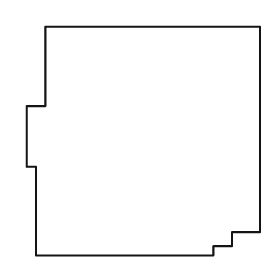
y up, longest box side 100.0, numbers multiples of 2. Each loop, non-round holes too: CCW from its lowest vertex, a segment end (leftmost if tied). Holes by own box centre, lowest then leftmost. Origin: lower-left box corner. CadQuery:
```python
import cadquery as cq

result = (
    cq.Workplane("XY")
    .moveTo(4.0, 0.0)
    .lineTo(80.0, 0.0)
    .lineTo(80.0, 4.0)
    .lineTo(88.0, 4.0)
    .lineTo(88.0, 10.0)
    .lineTo(100.0, 10.0)
    .lineTo(100.0, 98.0)
    .lineTo(8.0, 98.0)
    .lineTo(8.0, 64.0)
    .lineTo(0.0, 64.0)
    .lineTo(0.0, 38.0)
    .lineTo(4.0, 38.0)
    .close()
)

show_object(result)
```